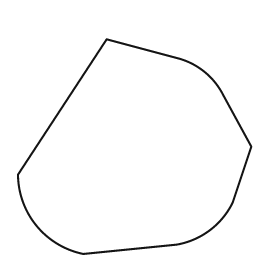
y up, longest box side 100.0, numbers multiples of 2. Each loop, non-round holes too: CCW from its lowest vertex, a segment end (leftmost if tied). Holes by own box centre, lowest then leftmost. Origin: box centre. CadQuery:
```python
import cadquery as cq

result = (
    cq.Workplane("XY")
    .moveTo(-22.0, -46.0)
    .lineTo(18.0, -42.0)
    .threePointArc((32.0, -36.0), (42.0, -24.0))
    .lineTo(50.0, 0.0)
    .lineTo(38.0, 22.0)
    .threePointArc((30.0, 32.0), (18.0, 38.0))
    .lineTo(-12.0, 46.0)
    .lineTo(-50.0, -12.0)
    .threePointArc((-42.0, -34.0), (-22.0, -46.0))
    .close()
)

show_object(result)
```